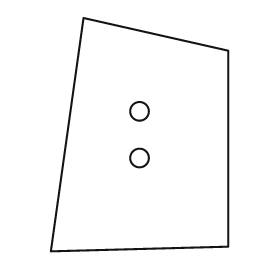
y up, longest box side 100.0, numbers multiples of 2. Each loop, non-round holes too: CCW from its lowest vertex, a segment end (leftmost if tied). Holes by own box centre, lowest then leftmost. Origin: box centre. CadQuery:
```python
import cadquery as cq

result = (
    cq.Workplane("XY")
    .moveTo(-38.0, -50.0)
    .lineTo(38.0, -48.0)
    .lineTo(38.0, 36.0)
    .lineTo(-24.0, 50.0)
    .close()
    .moveTo(0.0, -10.0)
    .circle(4.0)
    .moveTo(0.0, 10.0)
    .circle(4.0)
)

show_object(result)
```